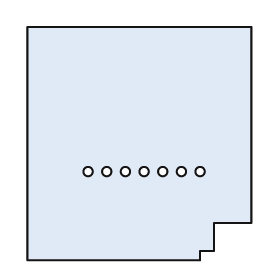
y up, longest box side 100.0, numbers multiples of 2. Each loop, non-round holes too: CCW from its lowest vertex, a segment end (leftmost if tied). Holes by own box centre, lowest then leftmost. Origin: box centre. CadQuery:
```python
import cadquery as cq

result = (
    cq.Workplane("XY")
    .moveTo(-48.0, -50.0)
    .lineTo(26.0, -50.0)
    .lineTo(26.0, -46.0)
    .lineTo(32.0, -46.0)
    .lineTo(32.0, -34.0)
    .lineTo(48.0, -34.0)
    .lineTo(48.0, 50.0)
    .lineTo(-48.0, 50.0)
    .close()
    .moveTo(-22.0, -12.0)
    .circle(2.0)
    .moveTo(-14.0, -12.0)
    .circle(2.0)
    .moveTo(-6.0, -12.0)
    .circle(2.0)
    .moveTo(2.0, -12.0)
    .circle(2.0)
    .moveTo(10.0, -12.0)
    .circle(2.0)
    .moveTo(18.0, -12.0)
    .circle(2.0)
    .moveTo(26.0, -12.0)
    .circle(2.0)
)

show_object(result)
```